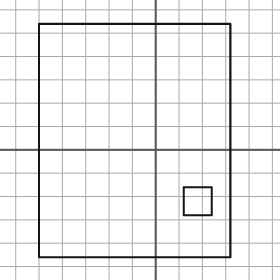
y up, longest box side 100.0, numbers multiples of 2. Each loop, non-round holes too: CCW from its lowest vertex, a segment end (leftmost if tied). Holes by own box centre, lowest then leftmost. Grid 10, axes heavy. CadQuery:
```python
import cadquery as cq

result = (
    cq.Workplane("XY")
    .moveTo(-50.0, -46.0)
    .lineTo(32.0, -46.0)
    .lineTo(32.0, 54.0)
    .lineTo(-50.0, 54.0)
    .close()
    .moveTo(12.0, -28.0)
    .lineTo(24.0, -28.0)
    .lineTo(24.0, -16.0)
    .lineTo(12.0, -16.0)
    .close()
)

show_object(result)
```